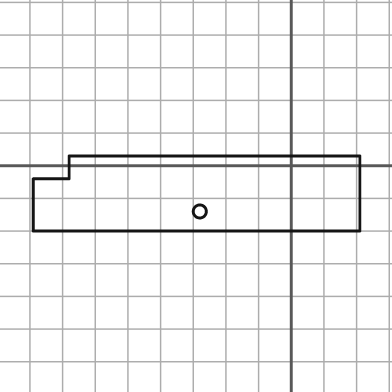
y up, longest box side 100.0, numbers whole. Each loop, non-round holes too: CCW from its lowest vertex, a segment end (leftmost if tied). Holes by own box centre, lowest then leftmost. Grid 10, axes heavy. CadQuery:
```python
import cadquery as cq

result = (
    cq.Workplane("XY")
    .moveTo(-79.0, -20.0)
    .lineTo(21.0, -20.0)
    .lineTo(21.0, 3.0)
    .lineTo(-68.0, 3.0)
    .lineTo(-68.0, -4.0)
    .lineTo(-79.0, -4.0)
    .close()
    .moveTo(-28.0, -14.0)
    .circle(2.0)
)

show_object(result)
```